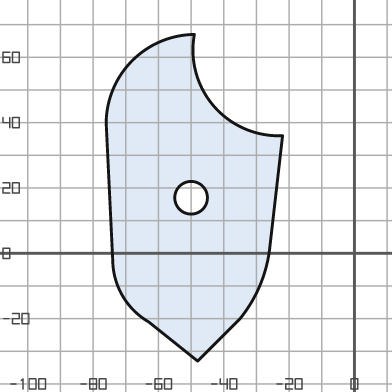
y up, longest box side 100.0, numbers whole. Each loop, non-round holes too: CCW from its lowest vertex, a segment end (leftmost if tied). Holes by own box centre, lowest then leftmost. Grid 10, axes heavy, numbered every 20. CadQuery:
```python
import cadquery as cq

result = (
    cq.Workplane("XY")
    .moveTo(-48.0, -33.0)
    .lineTo(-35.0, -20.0)
    .threePointArc((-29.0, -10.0), (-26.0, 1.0))
    .lineTo(-22.0, 36.0)
    .threePointArc((-43.0, 45.0), (-49.0, 67.0))
    .threePointArc((-68.0, 59.0), (-76.0, 40.0))
    .lineTo(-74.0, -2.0)
    .threePointArc((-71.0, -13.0), (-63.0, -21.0))
    .close()
    .moveTo(-50.0, 17.0)
    .circle(5.0)
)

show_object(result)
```